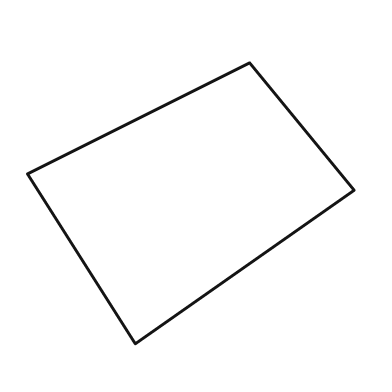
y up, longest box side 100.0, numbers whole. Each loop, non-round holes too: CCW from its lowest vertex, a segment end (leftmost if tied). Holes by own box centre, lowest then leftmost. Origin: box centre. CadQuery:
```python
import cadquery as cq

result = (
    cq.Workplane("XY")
    .moveTo(-17.0, -43.0)
    .lineTo(50.0, 4.0)
    .lineTo(18.0, 43.0)
    .lineTo(-50.0, 9.0)
    .close()
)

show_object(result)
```